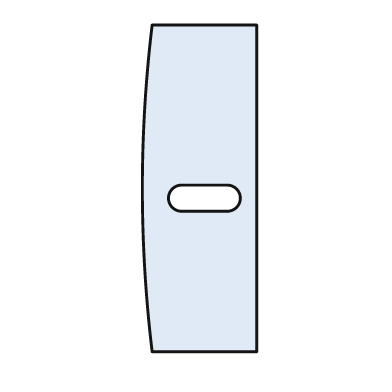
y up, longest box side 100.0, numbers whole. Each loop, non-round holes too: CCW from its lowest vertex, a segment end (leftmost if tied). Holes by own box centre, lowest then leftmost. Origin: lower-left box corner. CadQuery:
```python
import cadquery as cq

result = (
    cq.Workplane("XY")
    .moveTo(3.0, 0.0)
    .lineTo(35.0, 0.0)
    .lineTo(35.0, 100.0)
    .lineTo(3.0, 100.0)
    .threePointArc((0.0, 50.0), (3.0, 0.0))
    .close()
    .moveTo(12.0, 43.0)
    .lineTo(26.0, 43.0)
    .threePointArc((30.0, 47.0), (26.0, 51.0))
    .lineTo(12.0, 51.0)
    .threePointArc((8.0, 47.0), (12.0, 43.0))
    .close()
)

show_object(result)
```